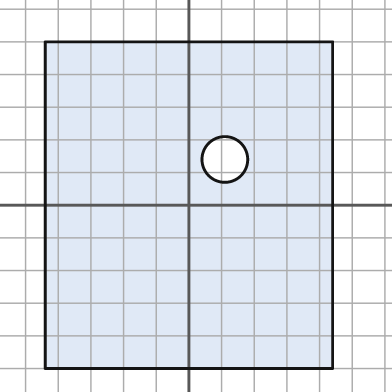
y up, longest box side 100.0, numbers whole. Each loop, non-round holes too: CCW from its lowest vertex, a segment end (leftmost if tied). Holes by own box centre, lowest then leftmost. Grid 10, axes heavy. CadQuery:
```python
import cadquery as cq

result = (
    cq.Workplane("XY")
    .moveTo(-44.0, -50.0)
    .lineTo(44.0, -50.0)
    .lineTo(44.0, 50.0)
    .lineTo(-44.0, 50.0)
    .close()
    .moveTo(11.0, 14.0)
    .circle(7.0)
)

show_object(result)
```